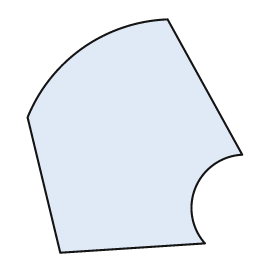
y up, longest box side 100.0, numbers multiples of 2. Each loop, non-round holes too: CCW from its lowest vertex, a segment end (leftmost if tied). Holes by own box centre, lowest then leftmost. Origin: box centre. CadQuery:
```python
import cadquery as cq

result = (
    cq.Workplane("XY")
    .moveTo(-32.0, -50.0)
    .lineTo(30.0, -46.0)
    .threePointArc((26.0, -22.0), (46.0, -8.0))
    .lineTo(14.0, 50.0)
    .threePointArc((-22.0, 38.0), (-46.0, 8.0))
    .close()
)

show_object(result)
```